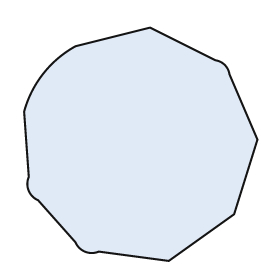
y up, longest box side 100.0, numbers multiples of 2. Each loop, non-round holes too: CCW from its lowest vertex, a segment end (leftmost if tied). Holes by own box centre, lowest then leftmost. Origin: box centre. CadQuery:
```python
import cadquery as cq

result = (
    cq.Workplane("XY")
    .moveTo(12.0, -50.0)
    .lineTo(40.0, -30.0)
    .lineTo(50.0, 2.0)
    .lineTo(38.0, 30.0)
    .threePointArc((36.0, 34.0), (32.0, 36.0))
    .lineTo(4.0, 50.0)
    .lineTo(-28.0, 42.0)
    .threePointArc((-42.0, 30.0), (-50.0, 14.0))
    .lineTo(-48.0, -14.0)
    .threePointArc((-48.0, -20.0), (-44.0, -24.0))
    .lineTo(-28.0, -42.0)
    .threePointArc((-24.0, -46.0), (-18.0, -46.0))
    .close()
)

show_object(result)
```